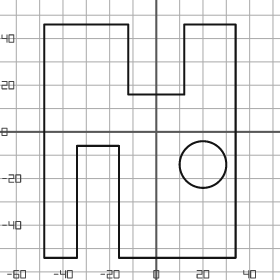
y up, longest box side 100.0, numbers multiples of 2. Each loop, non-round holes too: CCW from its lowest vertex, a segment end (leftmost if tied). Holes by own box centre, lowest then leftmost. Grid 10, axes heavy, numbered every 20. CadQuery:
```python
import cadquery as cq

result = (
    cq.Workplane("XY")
    .moveTo(-48.0, -54.0)
    .lineTo(-34.0, -54.0)
    .lineTo(-34.0, -6.0)
    .lineTo(-16.0, -6.0)
    .lineTo(-16.0, -54.0)
    .lineTo(34.0, -54.0)
    .lineTo(34.0, 46.0)
    .lineTo(12.0, 46.0)
    .lineTo(12.0, 16.0)
    .lineTo(-12.0, 16.0)
    .lineTo(-12.0, 46.0)
    .lineTo(-48.0, 46.0)
    .close()
    .moveTo(20.0, -14.0)
    .circle(10.0)
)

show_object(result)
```